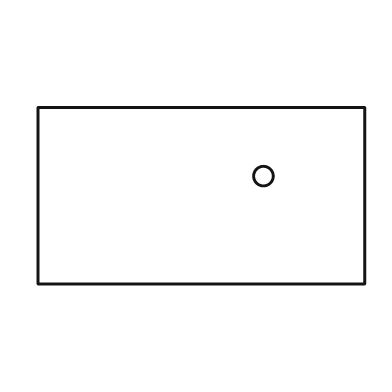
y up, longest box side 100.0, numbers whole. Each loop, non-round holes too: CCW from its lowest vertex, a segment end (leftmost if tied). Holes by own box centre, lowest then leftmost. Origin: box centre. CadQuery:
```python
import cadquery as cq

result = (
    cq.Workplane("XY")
    .moveTo(-50.0, -27.0)
    .lineTo(50.0, -27.0)
    .lineTo(50.0, 27.0)
    .lineTo(-50.0, 27.0)
    .close()
    .moveTo(19.0, 6.0)
    .circle(3.0)
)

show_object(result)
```